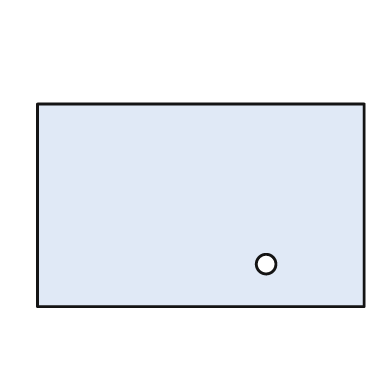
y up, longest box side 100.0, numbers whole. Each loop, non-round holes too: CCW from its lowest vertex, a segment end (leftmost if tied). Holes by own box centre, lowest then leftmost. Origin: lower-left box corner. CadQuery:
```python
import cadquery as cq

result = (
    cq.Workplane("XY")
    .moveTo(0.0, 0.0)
    .lineTo(100.0, 0.0)
    .lineTo(100.0, 62.0)
    .lineTo(0.0, 62.0)
    .close()
    .moveTo(70.0, 13.0)
    .circle(3.0)
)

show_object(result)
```